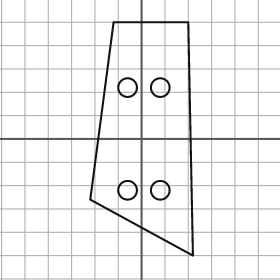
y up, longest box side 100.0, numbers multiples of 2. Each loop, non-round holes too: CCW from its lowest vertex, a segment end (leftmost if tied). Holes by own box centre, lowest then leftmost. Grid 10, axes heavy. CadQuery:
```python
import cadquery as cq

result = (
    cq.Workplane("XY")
    .moveTo(22.0, -50.0)
    .lineTo(20.0, 50.0)
    .lineTo(-12.0, 50.0)
    .lineTo(-22.0, -26.0)
    .close()
    .moveTo(-6.0, -22.0)
    .circle(4.0)
    .moveTo(8.0, -22.0)
    .circle(4.0)
    .moveTo(-6.0, 22.0)
    .circle(4.0)
    .moveTo(8.0, 22.0)
    .circle(4.0)
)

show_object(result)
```